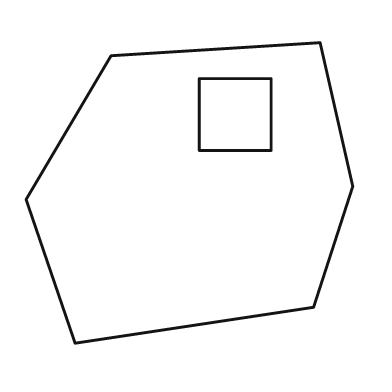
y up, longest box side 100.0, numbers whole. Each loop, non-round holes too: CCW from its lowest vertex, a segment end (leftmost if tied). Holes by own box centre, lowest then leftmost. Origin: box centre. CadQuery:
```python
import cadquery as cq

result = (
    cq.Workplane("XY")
    .moveTo(-35.0, -46.0)
    .lineTo(38.0, -35.0)
    .lineTo(50.0, 2.0)
    .lineTo(40.0, 46.0)
    .lineTo(-24.0, 42.0)
    .lineTo(-50.0, -2.0)
    .close()
    .moveTo(3.0, 13.0)
    .lineTo(25.0, 13.0)
    .lineTo(25.0, 35.0)
    .lineTo(3.0, 35.0)
    .close()
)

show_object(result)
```